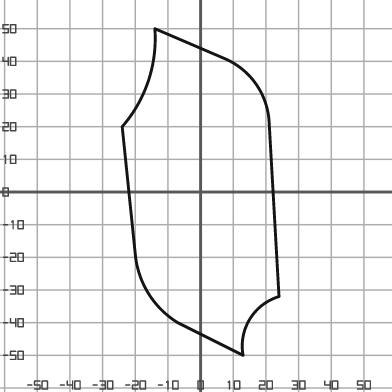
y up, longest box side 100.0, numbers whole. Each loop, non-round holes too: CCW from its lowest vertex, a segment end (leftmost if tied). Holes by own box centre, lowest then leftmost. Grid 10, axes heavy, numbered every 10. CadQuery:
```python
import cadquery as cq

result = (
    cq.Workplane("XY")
    .moveTo(13.0, -50.0)
    .threePointArc((15.0, -39.0), (24.0, -32.0))
    .lineTo(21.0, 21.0)
    .threePointArc((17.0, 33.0), (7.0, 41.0))
    .lineTo(-14.0, 50.0)
    .threePointArc((-16.0, 34.0), (-24.0, 20.0))
    .lineTo(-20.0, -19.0)
    .threePointArc((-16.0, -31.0), (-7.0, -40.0))
    .close()
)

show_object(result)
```